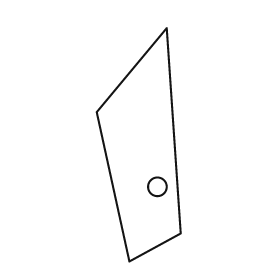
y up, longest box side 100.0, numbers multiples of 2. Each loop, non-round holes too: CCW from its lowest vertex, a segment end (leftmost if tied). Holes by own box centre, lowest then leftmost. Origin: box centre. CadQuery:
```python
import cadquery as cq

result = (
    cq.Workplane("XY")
    .moveTo(-4.0, -50.0)
    .lineTo(18.0, -38.0)
    .lineTo(12.0, 50.0)
    .lineTo(-18.0, 14.0)
    .close()
    .moveTo(8.0, -18.0)
    .circle(4.0)
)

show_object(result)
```